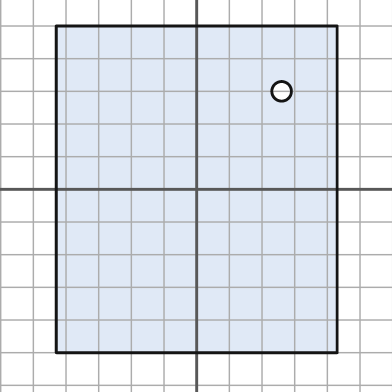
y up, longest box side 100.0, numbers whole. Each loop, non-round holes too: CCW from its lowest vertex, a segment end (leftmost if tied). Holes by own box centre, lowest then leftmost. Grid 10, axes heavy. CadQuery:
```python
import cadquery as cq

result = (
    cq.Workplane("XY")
    .moveTo(-43.0, -50.0)
    .lineTo(43.0, -50.0)
    .lineTo(43.0, 50.0)
    .lineTo(-43.0, 50.0)
    .close()
    .moveTo(26.0, 30.0)
    .circle(3.0)
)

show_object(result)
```